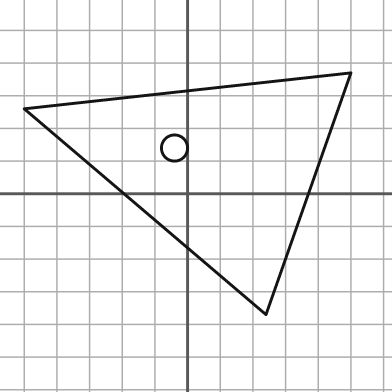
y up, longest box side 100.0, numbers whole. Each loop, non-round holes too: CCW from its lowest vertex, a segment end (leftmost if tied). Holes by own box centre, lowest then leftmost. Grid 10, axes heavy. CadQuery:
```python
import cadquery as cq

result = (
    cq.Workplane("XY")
    .moveTo(24.0, -37.0)
    .lineTo(50.0, 37.0)
    .lineTo(-50.0, 26.0)
    .close()
    .moveTo(-4.0, 14.0)
    .circle(4.0)
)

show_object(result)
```